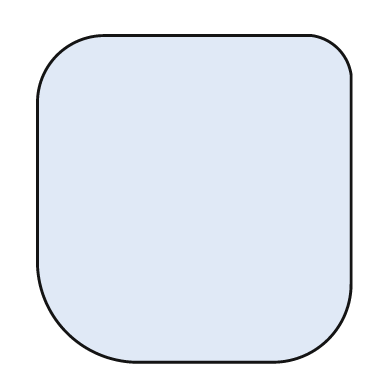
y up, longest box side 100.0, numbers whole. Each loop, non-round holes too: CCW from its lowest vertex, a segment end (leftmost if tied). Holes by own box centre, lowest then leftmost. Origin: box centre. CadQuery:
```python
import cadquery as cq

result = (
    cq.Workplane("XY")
    .moveTo(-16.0, -50.0)
    .lineTo(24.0, -50.0)
    .threePointArc((41.0, -43.0), (48.0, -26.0))
    .lineTo(48.0, 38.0)
    .threePointArc((44.0, 46.0), (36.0, 50.0))
    .lineTo(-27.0, 50.0)
    .threePointArc((-42.0, 44.0), (-48.0, 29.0))
    .lineTo(-48.0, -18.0)
    .threePointArc((-39.0, -41.0), (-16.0, -50.0))
    .close()
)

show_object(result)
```